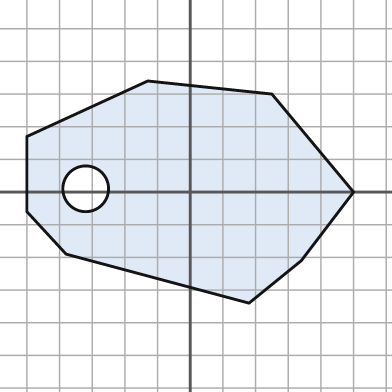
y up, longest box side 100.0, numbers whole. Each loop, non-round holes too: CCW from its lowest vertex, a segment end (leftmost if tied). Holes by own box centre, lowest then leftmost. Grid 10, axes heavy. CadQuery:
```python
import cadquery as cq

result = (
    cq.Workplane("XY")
    .moveTo(18.0, -34.0)
    .lineTo(34.0, -21.0)
    .lineTo(50.0, 0.0)
    .lineTo(25.0, 30.0)
    .lineTo(-13.0, 34.0)
    .lineTo(-50.0, 17.0)
    .lineTo(-50.0, -6.0)
    .lineTo(-38.0, -19.0)
    .close()
    .moveTo(-32.0, 1.0)
    .circle(7.0)
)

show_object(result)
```